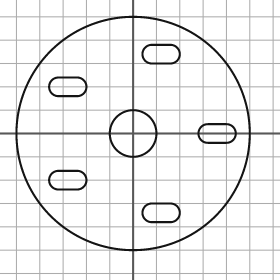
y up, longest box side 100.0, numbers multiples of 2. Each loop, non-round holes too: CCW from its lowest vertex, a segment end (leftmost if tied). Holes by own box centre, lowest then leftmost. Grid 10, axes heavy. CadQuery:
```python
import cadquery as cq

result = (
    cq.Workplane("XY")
    .moveTo(0.0, 0.0)
    .circle(50.0)
    .moveTo(8.0, -38.0)
    .lineTo(16.0, -38.0)
    .threePointArc((20.0, -34.0), (16.0, -30.0))
    .lineTo(8.0, -30.0)
    .threePointArc((4.0, -34.0), (8.0, -38.0))
    .close()
    .moveTo(-32.0, -24.0)
    .lineTo(-24.0, -24.0)
    .threePointArc((-20.0, -20.0), (-24.0, -16.0))
    .lineTo(-32.0, -16.0)
    .threePointArc((-36.0, -20.0), (-32.0, -24.0))
    .close()
    .moveTo(0.0, 0.0)
    .circle(10.0)
    .moveTo(32.0, -4.0)
    .lineTo(40.0, -4.0)
    .threePointArc((44.0, 0.0), (40.0, 4.0))
    .lineTo(32.0, 4.0)
    .threePointArc((28.0, 0.0), (32.0, -4.0))
    .close()
    .moveTo(-32.0, 16.0)
    .lineTo(-24.0, 16.0)
    .threePointArc((-20.0, 20.0), (-24.0, 24.0))
    .lineTo(-32.0, 24.0)
    .threePointArc((-36.0, 20.0), (-32.0, 16.0))
    .close()
    .moveTo(8.0, 30.0)
    .lineTo(16.0, 30.0)
    .threePointArc((20.0, 34.0), (16.0, 38.0))
    .lineTo(8.0, 38.0)
    .threePointArc((4.0, 34.0), (8.0, 30.0))
    .close()
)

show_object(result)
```